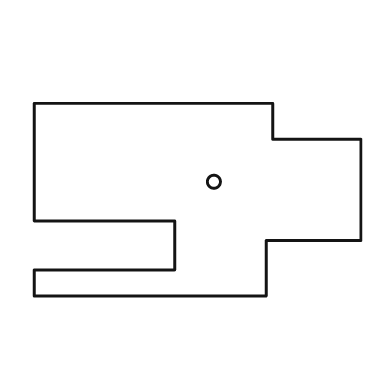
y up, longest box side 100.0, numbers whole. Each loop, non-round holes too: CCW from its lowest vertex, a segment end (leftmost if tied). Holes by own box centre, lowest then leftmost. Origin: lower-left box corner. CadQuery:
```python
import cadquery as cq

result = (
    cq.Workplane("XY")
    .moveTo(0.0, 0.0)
    .lineTo(71.0, 0.0)
    .lineTo(71.0, 17.0)
    .lineTo(100.0, 17.0)
    .lineTo(100.0, 48.0)
    .lineTo(73.0, 48.0)
    .lineTo(73.0, 59.0)
    .lineTo(0.0, 59.0)
    .lineTo(0.0, 23.0)
    .lineTo(43.0, 23.0)
    .lineTo(43.0, 8.0)
    .lineTo(0.0, 8.0)
    .close()
    .moveTo(55.0, 35.0)
    .circle(2.0)
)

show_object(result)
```